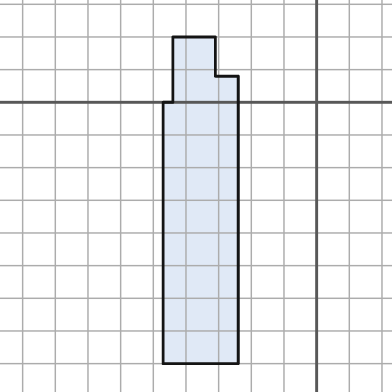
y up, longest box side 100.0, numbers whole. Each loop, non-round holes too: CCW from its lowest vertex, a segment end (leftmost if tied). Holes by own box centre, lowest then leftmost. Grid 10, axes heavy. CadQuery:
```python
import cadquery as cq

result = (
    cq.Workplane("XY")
    .moveTo(-47.0, -80.0)
    .lineTo(-24.0, -80.0)
    .lineTo(-24.0, 8.0)
    .lineTo(-31.0, 8.0)
    .lineTo(-31.0, 20.0)
    .lineTo(-44.0, 20.0)
    .lineTo(-44.0, 0.0)
    .lineTo(-47.0, 0.0)
    .close()
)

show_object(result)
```